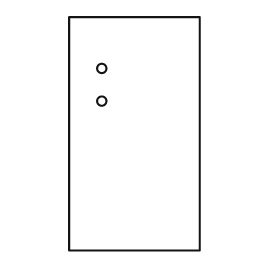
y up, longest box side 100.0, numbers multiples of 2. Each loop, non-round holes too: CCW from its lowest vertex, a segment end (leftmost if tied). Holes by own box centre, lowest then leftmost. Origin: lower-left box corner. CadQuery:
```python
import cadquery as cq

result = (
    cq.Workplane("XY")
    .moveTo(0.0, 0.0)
    .lineTo(56.0, 0.0)
    .lineTo(56.0, 100.0)
    .lineTo(0.0, 100.0)
    .close()
    .moveTo(14.0, 64.0)
    .circle(2.0)
    .moveTo(14.0, 78.0)
    .circle(2.0)
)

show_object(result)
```